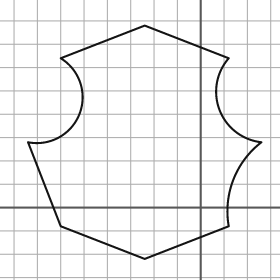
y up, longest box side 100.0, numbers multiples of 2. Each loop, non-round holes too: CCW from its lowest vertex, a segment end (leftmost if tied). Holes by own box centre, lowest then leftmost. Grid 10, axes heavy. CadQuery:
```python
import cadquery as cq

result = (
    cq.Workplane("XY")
    .moveTo(-24.0, -22.0)
    .lineTo(12.0, -8.0)
    .threePointArc((14.0, 12.0), (26.0, 28.0))
    .threePointArc((8.0, 42.0), (12.0, 64.0))
    .lineTo(-24.0, 78.0)
    .lineTo(-60.0, 64.0)
    .threePointArc((-52.0, 40.0), (-74.0, 28.0))
    .lineTo(-60.0, -8.0)
    .close()
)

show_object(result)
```